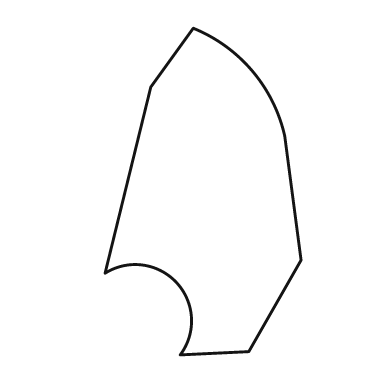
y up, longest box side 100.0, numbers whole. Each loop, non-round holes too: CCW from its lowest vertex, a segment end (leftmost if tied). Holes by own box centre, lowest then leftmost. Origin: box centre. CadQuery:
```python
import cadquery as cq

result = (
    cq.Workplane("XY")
    .moveTo(-7.0, -50.0)
    .lineTo(14.0, -49.0)
    .lineTo(30.0, -21.0)
    .lineTo(25.0, 17.0)
    .threePointArc((15.0, 37.0), (-3.0, 50.0))
    .lineTo(-16.0, 32.0)
    .lineTo(-30.0, -25.0)
    .threePointArc((-8.0, -28.0), (-7.0, -50.0))
    .close()
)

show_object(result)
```